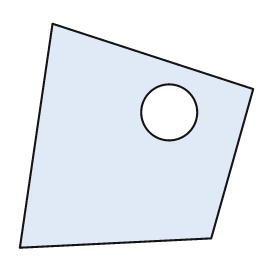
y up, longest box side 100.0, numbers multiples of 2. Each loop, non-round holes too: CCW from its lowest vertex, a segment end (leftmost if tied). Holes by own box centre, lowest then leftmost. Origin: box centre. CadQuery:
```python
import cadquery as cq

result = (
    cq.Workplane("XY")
    .moveTo(-50.0, -48.0)
    .lineTo(32.0, -44.0)
    .lineTo(50.0, 20.0)
    .lineTo(-36.0, 48.0)
    .close()
    .moveTo(14.0, 10.0)
    .circle(12.0)
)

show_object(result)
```